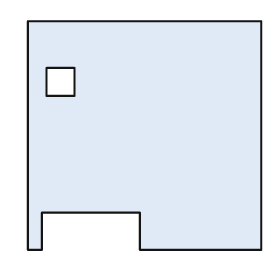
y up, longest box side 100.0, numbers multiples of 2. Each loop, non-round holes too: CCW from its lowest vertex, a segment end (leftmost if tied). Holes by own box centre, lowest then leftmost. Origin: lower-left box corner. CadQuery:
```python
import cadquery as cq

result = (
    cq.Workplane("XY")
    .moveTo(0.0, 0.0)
    .lineTo(6.0, 0.0)
    .lineTo(6.0, 16.0)
    .lineTo(48.0, 16.0)
    .lineTo(48.0, 0.0)
    .lineTo(100.0, 0.0)
    .lineTo(100.0, 98.0)
    .lineTo(0.0, 98.0)
    .close()
    .moveTo(8.0, 66.0)
    .lineTo(20.0, 66.0)
    .lineTo(20.0, 78.0)
    .lineTo(8.0, 78.0)
    .close()
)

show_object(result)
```